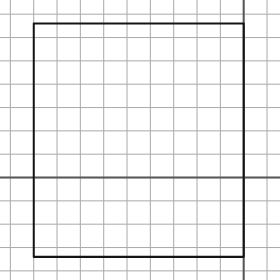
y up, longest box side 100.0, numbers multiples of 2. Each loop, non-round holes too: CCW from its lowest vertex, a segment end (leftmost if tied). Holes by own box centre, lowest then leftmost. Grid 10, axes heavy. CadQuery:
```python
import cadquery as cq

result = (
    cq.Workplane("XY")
    .moveTo(-90.0, -34.0)
    .lineTo(0.0, -34.0)
    .lineTo(0.0, 66.0)
    .lineTo(-90.0, 66.0)
    .close()
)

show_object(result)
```